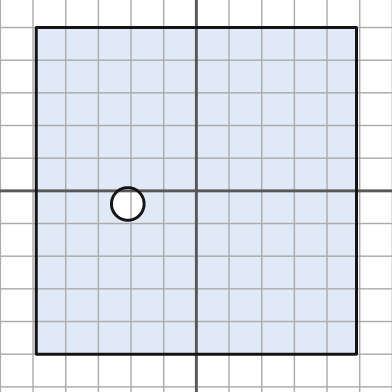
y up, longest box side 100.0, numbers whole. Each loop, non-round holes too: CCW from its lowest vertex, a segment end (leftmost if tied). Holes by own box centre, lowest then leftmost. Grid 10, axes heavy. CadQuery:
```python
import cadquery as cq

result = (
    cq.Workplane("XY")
    .moveTo(-49.0, -50.0)
    .lineTo(49.0, -50.0)
    .lineTo(49.0, 50.0)
    .lineTo(-49.0, 50.0)
    .close()
    .moveTo(-21.0, -4.0)
    .circle(5.0)
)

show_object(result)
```